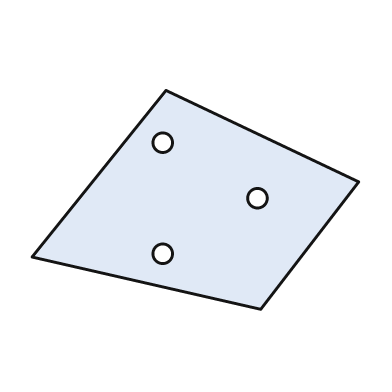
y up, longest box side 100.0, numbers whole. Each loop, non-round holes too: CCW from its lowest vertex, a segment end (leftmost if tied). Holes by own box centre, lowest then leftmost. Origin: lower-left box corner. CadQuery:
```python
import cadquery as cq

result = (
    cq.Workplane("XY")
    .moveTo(70.0, 0.0)
    .lineTo(100.0, 39.0)
    .lineTo(41.0, 67.0)
    .lineTo(0.0, 16.0)
    .close()
    .moveTo(40.0, 17.0)
    .circle(3.0)
    .moveTo(69.0, 34.0)
    .circle(3.0)
    .moveTo(40.0, 51.0)
    .circle(3.0)
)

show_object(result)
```